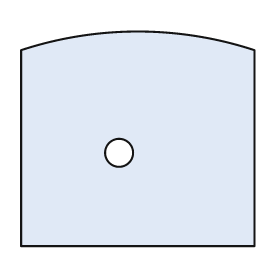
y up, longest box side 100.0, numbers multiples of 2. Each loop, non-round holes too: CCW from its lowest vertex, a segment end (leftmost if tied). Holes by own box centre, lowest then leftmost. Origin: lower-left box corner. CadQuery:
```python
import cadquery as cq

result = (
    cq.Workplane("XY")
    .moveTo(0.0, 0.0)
    .lineTo(100.0, 0.0)
    .lineTo(100.0, 84.0)
    .threePointArc((50.0, 92.0), (0.0, 84.0))
    .close()
    .moveTo(42.0, 40.0)
    .circle(6.0)
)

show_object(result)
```